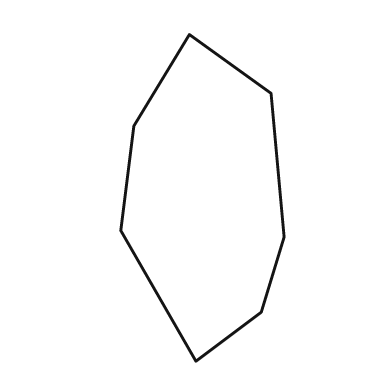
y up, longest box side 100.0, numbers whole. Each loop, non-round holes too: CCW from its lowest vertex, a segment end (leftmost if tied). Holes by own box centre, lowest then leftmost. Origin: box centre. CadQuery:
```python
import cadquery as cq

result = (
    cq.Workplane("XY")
    .moveTo(-2.0, -50.0)
    .lineTo(18.0, -35.0)
    .lineTo(25.0, -12.0)
    .lineTo(21.0, 32.0)
    .lineTo(-4.0, 50.0)
    .lineTo(-21.0, 22.0)
    .lineTo(-25.0, -10.0)
    .close()
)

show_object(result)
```